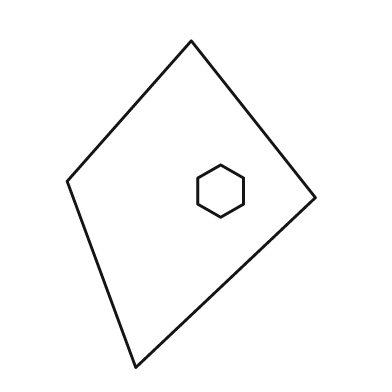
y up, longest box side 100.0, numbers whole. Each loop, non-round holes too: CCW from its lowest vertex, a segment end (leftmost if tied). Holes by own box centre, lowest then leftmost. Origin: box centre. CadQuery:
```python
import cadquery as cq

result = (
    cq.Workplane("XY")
    .moveTo(-17.0, -50.0)
    .lineTo(38.0, 2.0)
    .lineTo(0.0, 50.0)
    .lineTo(-38.0, 7.0)
    .close()
    .moveTo(9.0, -4.0)
    .lineTo(16.0, 0.0)
    .lineTo(16.0, 8.0)
    .lineTo(9.0, 12.0)
    .lineTo(2.0, 8.0)
    .lineTo(2.0, 0.0)
    .close()
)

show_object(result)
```